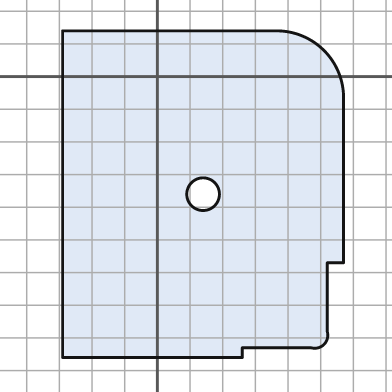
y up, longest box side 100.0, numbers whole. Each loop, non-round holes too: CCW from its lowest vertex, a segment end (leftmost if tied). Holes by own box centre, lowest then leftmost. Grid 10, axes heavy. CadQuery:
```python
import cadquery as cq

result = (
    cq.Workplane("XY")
    .moveTo(-29.0, -86.0)
    .lineTo(26.0, -86.0)
    .lineTo(26.0, -83.0)
    .lineTo(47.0, -83.0)
    .threePointArc((51.0, -82.0), (52.0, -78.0))
    .lineTo(52.0, -57.0)
    .lineTo(57.0, -57.0)
    .lineTo(57.0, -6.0)
    .threePointArc((51.0, 8.0), (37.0, 14.0))
    .lineTo(-29.0, 14.0)
    .close()
    .moveTo(14.0, -36.0)
    .circle(5.0)
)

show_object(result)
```